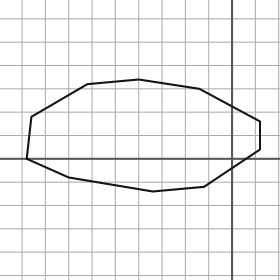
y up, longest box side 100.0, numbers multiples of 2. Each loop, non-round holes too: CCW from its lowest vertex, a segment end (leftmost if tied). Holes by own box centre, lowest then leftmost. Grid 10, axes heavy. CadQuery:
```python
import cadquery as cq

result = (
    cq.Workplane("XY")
    .moveTo(-34.0, -14.0)
    .lineTo(-12.0, -12.0)
    .lineTo(12.0, 4.0)
    .lineTo(12.0, 16.0)
    .lineTo(-14.0, 30.0)
    .lineTo(-40.0, 34.0)
    .lineTo(-62.0, 32.0)
    .lineTo(-86.0, 18.0)
    .lineTo(-88.0, 0.0)
    .lineTo(-70.0, -8.0)
    .close()
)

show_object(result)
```